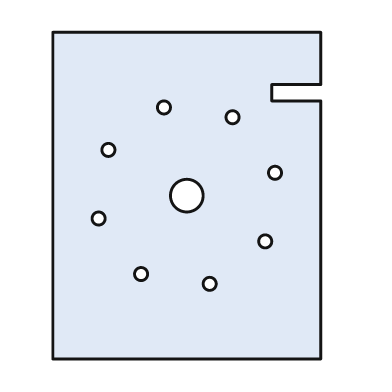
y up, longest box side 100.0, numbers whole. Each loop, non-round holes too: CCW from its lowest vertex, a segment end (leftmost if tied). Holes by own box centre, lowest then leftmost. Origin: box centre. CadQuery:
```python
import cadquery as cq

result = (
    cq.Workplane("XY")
    .moveTo(-41.0, -50.0)
    .lineTo(41.0, -50.0)
    .lineTo(41.0, 29.0)
    .lineTo(26.0, 29.0)
    .lineTo(26.0, 34.0)
    .lineTo(41.0, 34.0)
    .lineTo(41.0, 50.0)
    .lineTo(-41.0, 50.0)
    .close()
    .moveTo(7.0, -27.0)
    .circle(2.0)
    .moveTo(-14.0, -24.0)
    .circle(2.0)
    .moveTo(24.0, -14.0)
    .circle(2.0)
    .moveTo(-27.0, -7.0)
    .circle(2.0)
    .moveTo(0.0, 0.0)
    .circle(5.0)
    .moveTo(27.0, 7.0)
    .circle(2.0)
    .moveTo(-24.0, 14.0)
    .circle(2.0)
    .moveTo(14.0, 24.0)
    .circle(2.0)
    .moveTo(-7.0, 27.0)
    .circle(2.0)
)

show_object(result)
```